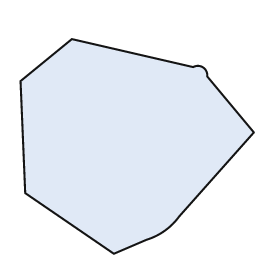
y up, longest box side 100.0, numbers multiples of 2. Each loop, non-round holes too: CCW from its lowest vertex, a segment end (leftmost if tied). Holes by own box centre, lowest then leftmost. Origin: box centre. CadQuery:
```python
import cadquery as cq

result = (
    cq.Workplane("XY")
    .moveTo(-10.0, -46.0)
    .lineTo(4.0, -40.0)
    .threePointArc((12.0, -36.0), (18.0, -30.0))
    .lineTo(50.0, 6.0)
    .lineTo(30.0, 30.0)
    .threePointArc((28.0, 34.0), (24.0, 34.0))
    .lineTo(-28.0, 46.0)
    .lineTo(-50.0, 28.0)
    .lineTo(-48.0, -20.0)
    .close()
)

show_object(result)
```